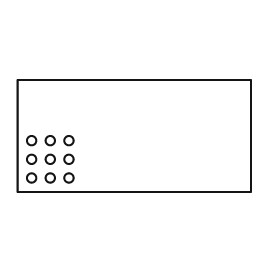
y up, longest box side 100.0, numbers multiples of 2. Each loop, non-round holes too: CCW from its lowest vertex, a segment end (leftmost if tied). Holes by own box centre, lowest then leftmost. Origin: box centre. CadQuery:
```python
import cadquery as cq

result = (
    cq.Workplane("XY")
    .moveTo(-50.0, -24.0)
    .lineTo(50.0, -24.0)
    .lineTo(50.0, 24.0)
    .lineTo(-50.0, 24.0)
    .close()
    .moveTo(-44.0, -18.0)
    .circle(2.0)
    .moveTo(-36.0, -18.0)
    .circle(2.0)
    .moveTo(-28.0, -18.0)
    .circle(2.0)
    .moveTo(-44.0, -10.0)
    .circle(2.0)
    .moveTo(-36.0, -10.0)
    .circle(2.0)
    .moveTo(-28.0, -10.0)
    .circle(2.0)
    .moveTo(-44.0, -2.0)
    .circle(2.0)
    .moveTo(-36.0, -2.0)
    .circle(2.0)
    .moveTo(-28.0, -2.0)
    .circle(2.0)
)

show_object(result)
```